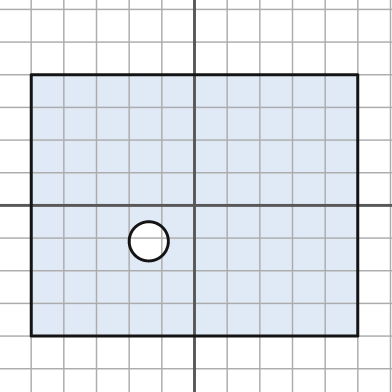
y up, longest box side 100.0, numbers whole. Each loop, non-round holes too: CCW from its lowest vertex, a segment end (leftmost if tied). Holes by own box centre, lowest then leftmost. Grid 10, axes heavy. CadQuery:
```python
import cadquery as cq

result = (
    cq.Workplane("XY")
    .moveTo(-50.0, -40.0)
    .lineTo(50.0, -40.0)
    .lineTo(50.0, 40.0)
    .lineTo(-50.0, 40.0)
    .close()
    .moveTo(-14.0, -11.0)
    .circle(6.0)
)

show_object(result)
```